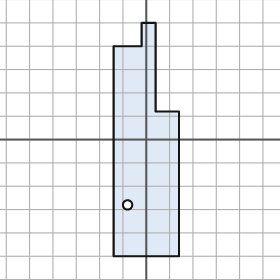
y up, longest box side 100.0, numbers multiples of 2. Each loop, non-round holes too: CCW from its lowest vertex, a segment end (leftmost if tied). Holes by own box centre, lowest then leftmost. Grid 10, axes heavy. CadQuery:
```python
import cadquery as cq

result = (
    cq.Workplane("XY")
    .moveTo(-14.0, -50.0)
    .lineTo(14.0, -50.0)
    .lineTo(14.0, 12.0)
    .lineTo(4.0, 12.0)
    .lineTo(4.0, 50.0)
    .lineTo(-2.0, 50.0)
    .lineTo(-2.0, 40.0)
    .lineTo(-14.0, 40.0)
    .close()
    .moveTo(-8.0, -28.0)
    .circle(2.0)
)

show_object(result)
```